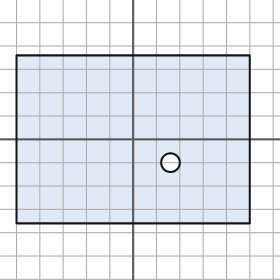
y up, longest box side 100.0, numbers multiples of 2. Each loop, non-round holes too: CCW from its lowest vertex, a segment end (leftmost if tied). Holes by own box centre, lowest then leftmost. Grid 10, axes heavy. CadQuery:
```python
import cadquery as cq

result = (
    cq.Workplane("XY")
    .moveTo(-50.0, -36.0)
    .lineTo(50.0, -36.0)
    .lineTo(50.0, 36.0)
    .lineTo(-50.0, 36.0)
    .close()
    .moveTo(16.0, -10.0)
    .circle(4.0)
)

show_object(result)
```